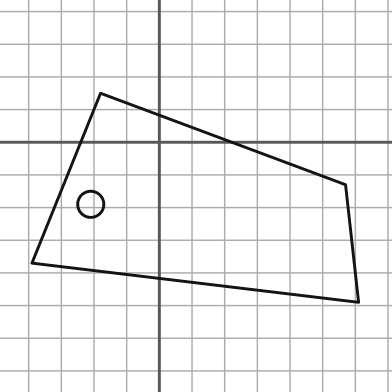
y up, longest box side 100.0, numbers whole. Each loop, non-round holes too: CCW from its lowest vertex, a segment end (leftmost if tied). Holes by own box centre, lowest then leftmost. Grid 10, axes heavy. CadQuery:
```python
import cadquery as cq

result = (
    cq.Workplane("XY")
    .moveTo(61.0, -49.0)
    .lineTo(57.0, -13.0)
    .lineTo(-18.0, 15.0)
    .lineTo(-39.0, -37.0)
    .close()
    .moveTo(-21.0, -19.0)
    .circle(4.0)
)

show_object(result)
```